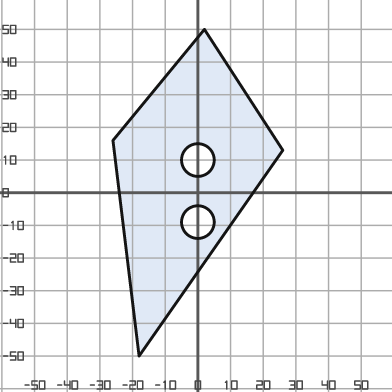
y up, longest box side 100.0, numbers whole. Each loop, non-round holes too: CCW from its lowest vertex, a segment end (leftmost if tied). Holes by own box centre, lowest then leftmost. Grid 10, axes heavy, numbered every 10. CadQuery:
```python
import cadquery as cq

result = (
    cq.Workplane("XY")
    .moveTo(-18.0, -50.0)
    .lineTo(26.0, 13.0)
    .lineTo(2.0, 50.0)
    .lineTo(-26.0, 16.0)
    .close()
    .moveTo(0.0, -9.0)
    .circle(5.0)
    .moveTo(0.0, 10.0)
    .circle(5.0)
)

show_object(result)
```